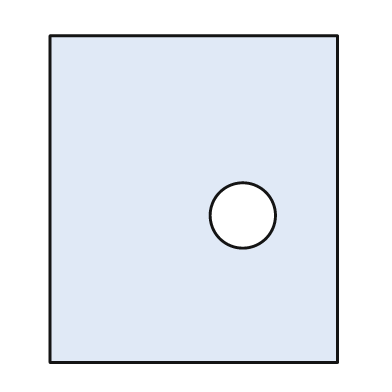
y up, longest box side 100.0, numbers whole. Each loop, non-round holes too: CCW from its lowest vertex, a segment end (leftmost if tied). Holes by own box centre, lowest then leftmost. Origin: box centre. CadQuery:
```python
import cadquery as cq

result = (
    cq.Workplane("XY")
    .moveTo(-44.0, -50.0)
    .lineTo(44.0, -50.0)
    .lineTo(44.0, 50.0)
    .lineTo(-44.0, 50.0)
    .close()
    .moveTo(15.0, -5.0)
    .circle(10.0)
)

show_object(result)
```